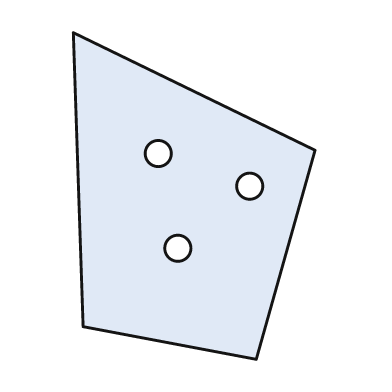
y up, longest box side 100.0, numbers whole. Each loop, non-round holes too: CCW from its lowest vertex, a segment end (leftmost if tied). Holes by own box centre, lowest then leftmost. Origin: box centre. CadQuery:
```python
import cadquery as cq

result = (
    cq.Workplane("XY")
    .moveTo(19.0, -50.0)
    .lineTo(37.0, 14.0)
    .lineTo(-37.0, 50.0)
    .lineTo(-34.0, -40.0)
    .close()
    .moveTo(-5.0, -16.0)
    .circle(4.0)
    .moveTo(17.0, 3.0)
    .circle(4.0)
    .moveTo(-11.0, 13.0)
    .circle(4.0)
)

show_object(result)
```